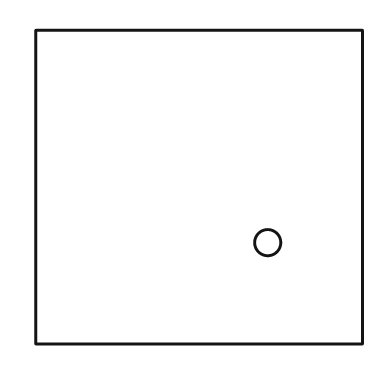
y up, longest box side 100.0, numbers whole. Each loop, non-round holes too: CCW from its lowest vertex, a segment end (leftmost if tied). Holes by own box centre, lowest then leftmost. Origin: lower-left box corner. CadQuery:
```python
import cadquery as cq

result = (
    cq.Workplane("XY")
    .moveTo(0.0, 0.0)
    .lineTo(100.0, 0.0)
    .lineTo(100.0, 96.0)
    .lineTo(0.0, 96.0)
    .close()
    .moveTo(71.0, 31.0)
    .circle(4.0)
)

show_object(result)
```